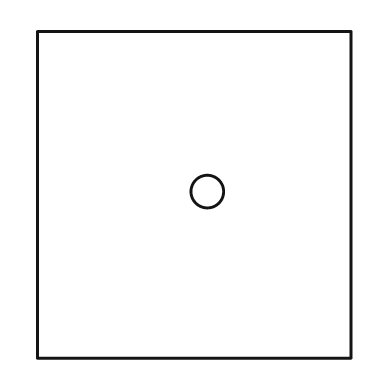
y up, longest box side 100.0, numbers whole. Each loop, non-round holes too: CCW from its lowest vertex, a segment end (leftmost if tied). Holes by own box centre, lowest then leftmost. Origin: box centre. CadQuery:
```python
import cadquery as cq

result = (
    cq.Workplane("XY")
    .moveTo(-48.0, -50.0)
    .lineTo(48.0, -50.0)
    .lineTo(48.0, 50.0)
    .lineTo(-48.0, 50.0)
    .close()
    .moveTo(4.0, 1.0)
    .circle(5.0)
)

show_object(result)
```